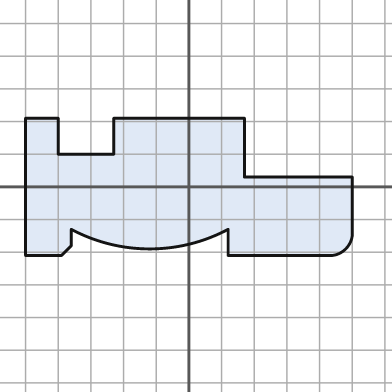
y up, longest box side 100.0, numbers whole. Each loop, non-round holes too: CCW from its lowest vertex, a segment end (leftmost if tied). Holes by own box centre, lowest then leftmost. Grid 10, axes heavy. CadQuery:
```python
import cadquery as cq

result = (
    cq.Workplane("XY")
    .moveTo(-50.0, -21.0)
    .lineTo(-39.0, -21.0)
    .lineTo(-36.0, -18.0)
    .lineTo(-36.0, -13.0)
    .threePointArc((-12.0, -19.0), (12.0, -13.0))
    .lineTo(12.0, -21.0)
    .lineTo(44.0, -21.0)
    .threePointArc((48.0, -19.0), (50.0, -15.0))
    .lineTo(50.0, 3.0)
    .lineTo(17.0, 3.0)
    .lineTo(17.0, 21.0)
    .lineTo(-23.0, 21.0)
    .lineTo(-23.0, 10.0)
    .lineTo(-40.0, 10.0)
    .lineTo(-40.0, 21.0)
    .lineTo(-50.0, 21.0)
    .close()
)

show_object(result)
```